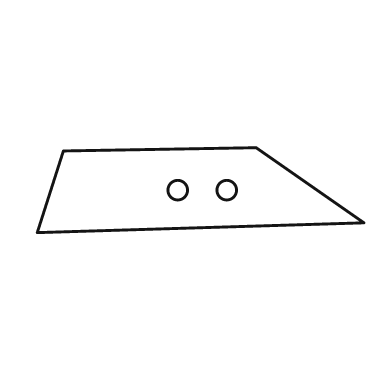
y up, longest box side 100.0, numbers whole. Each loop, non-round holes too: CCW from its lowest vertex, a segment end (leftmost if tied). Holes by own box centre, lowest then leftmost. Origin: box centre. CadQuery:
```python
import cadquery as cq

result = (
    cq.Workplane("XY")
    .moveTo(-50.0, -13.0)
    .lineTo(50.0, -10.0)
    .lineTo(17.0, 13.0)
    .lineTo(-42.0, 12.0)
    .close()
    .moveTo(-7.0, 0.0)
    .circle(3.0)
    .moveTo(8.0, 0.0)
    .circle(3.0)
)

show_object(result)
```